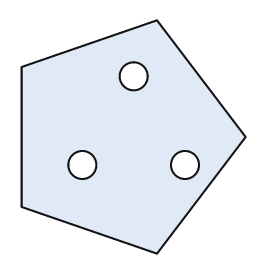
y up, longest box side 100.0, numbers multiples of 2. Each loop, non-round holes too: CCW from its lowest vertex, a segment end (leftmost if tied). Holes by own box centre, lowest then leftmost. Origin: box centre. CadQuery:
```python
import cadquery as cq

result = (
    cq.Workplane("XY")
    .moveTo(10.0, -50.0)
    .lineTo(48.0, 0.0)
    .lineTo(10.0, 50.0)
    .lineTo(-48.0, 30.0)
    .lineTo(-48.0, -30.0)
    .close()
    .moveTo(-22.0, -12.0)
    .circle(6.0)
    .moveTo(22.0, -12.0)
    .circle(6.0)
    .moveTo(0.0, 26.0)
    .circle(6.0)
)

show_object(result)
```